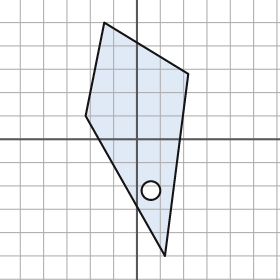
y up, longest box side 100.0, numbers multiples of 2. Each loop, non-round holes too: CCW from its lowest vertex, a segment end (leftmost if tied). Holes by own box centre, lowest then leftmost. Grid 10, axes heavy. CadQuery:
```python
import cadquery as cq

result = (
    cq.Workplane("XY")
    .moveTo(12.0, -50.0)
    .lineTo(22.0, 28.0)
    .lineTo(-14.0, 50.0)
    .lineTo(-22.0, 10.0)
    .close()
    .moveTo(6.0, -22.0)
    .circle(4.0)
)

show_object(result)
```